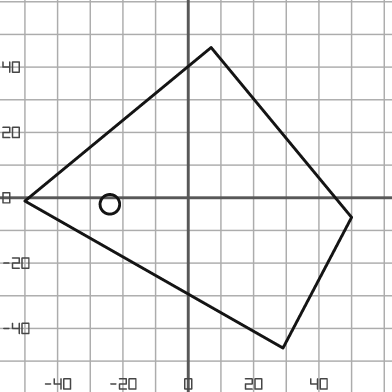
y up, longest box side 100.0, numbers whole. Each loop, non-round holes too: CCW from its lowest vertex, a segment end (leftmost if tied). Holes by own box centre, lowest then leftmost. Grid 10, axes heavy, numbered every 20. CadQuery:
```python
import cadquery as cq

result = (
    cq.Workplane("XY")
    .moveTo(29.0, -46.0)
    .lineTo(50.0, -6.0)
    .lineTo(7.0, 46.0)
    .lineTo(-50.0, -1.0)
    .close()
    .moveTo(-24.0, -2.0)
    .circle(3.0)
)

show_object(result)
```